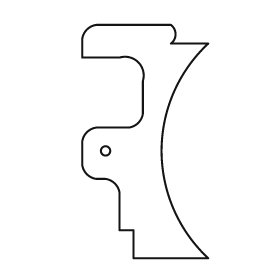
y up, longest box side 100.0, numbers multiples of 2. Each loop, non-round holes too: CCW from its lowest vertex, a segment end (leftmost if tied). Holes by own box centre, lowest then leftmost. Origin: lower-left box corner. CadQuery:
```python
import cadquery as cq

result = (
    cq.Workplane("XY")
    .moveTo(22.0, 0.0)
    .lineTo(54.0, 0.0)
    .threePointArc((34.0, 46.0), (54.0, 92.0))
    .lineTo(38.0, 92.0)
    .threePointArc((40.0, 96.0), (38.0, 100.0))
    .lineTo(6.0, 100.0)
    .threePointArc((2.0, 98.0), (0.0, 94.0))
    .lineTo(0.0, 86.0)
    .lineTo(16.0, 86.0)
    .threePointArc((24.0, 84.0), (26.0, 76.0))
    .lineTo(26.0, 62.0)
    .threePointArc((24.0, 58.0), (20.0, 56.0))
    .lineTo(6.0, 56.0)
    .threePointArc((2.0, 54.0), (0.0, 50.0))
    .lineTo(0.0, 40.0)
    .threePointArc((2.0, 36.0), (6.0, 34.0))
    .lineTo(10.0, 34.0)
    .threePointArc((14.0, 32.0), (16.0, 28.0))
    .lineTo(16.0, 12.0)
    .lineTo(22.0, 12.0)
    .close()
    .moveTo(10.0, 46.0)
    .circle(2.0)
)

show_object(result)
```